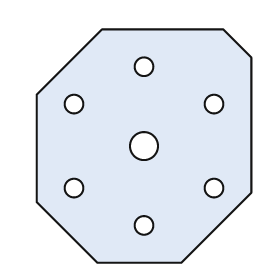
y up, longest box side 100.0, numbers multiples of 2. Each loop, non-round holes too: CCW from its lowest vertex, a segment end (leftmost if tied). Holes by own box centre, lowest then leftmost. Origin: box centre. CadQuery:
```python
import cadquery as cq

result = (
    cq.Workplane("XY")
    .moveTo(-20.0, -50.0)
    .lineTo(16.0, -50.0)
    .lineTo(46.0, -20.0)
    .lineTo(46.0, 38.0)
    .lineTo(34.0, 50.0)
    .lineTo(-18.0, 50.0)
    .lineTo(-46.0, 22.0)
    .lineTo(-46.0, -24.0)
    .close()
    .moveTo(0.0, -34.0)
    .circle(4.0)
    .moveTo(-30.0, -18.0)
    .circle(4.0)
    .moveTo(30.0, -18.0)
    .circle(4.0)
    .moveTo(0.0, 0.0)
    .circle(6.0)
    .moveTo(-30.0, 18.0)
    .circle(4.0)
    .moveTo(30.0, 18.0)
    .circle(4.0)
    .moveTo(0.0, 34.0)
    .circle(4.0)
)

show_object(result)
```